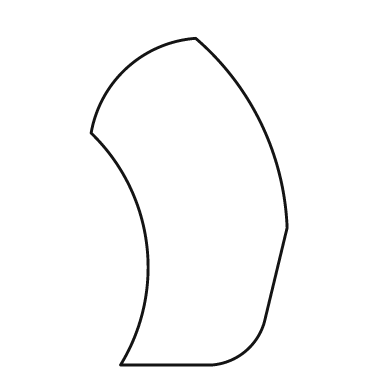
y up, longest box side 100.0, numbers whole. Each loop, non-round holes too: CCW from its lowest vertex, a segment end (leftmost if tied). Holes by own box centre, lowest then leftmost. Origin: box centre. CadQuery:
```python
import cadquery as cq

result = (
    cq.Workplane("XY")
    .moveTo(-21.0, -50.0)
    .lineTo(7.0, -50.0)
    .threePointArc((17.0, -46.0), (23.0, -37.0))
    .lineTo(30.0, -8.0)
    .threePointArc((22.0, 24.0), (2.0, 50.0))
    .threePointArc((-19.0, 41.0), (-30.0, 21.0))
    .threePointArc((-13.0, -13.0), (-21.0, -50.0))
    .close()
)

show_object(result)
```